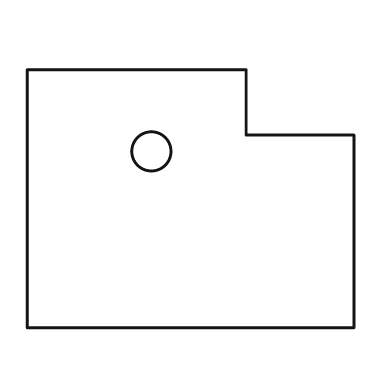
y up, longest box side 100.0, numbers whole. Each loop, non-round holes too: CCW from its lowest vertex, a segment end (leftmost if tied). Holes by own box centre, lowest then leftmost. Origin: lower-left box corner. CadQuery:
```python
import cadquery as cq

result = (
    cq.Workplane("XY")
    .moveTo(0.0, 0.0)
    .lineTo(100.0, 0.0)
    .lineTo(100.0, 59.0)
    .lineTo(67.0, 59.0)
    .lineTo(67.0, 79.0)
    .lineTo(0.0, 79.0)
    .close()
    .moveTo(38.0, 54.0)
    .circle(6.0)
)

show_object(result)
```